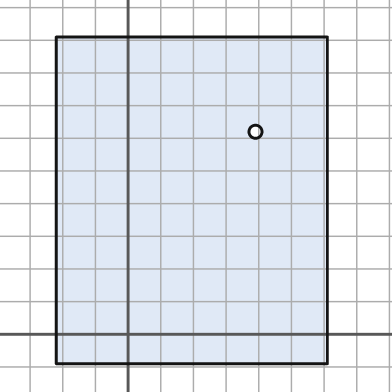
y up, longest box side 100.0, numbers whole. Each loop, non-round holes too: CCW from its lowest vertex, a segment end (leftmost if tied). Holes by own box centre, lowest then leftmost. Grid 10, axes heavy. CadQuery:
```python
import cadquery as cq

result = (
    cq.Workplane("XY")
    .moveTo(-22.0, -9.0)
    .lineTo(61.0, -9.0)
    .lineTo(61.0, 91.0)
    .lineTo(-22.0, 91.0)
    .close()
    .moveTo(39.0, 62.0)
    .circle(2.0)
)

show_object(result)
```